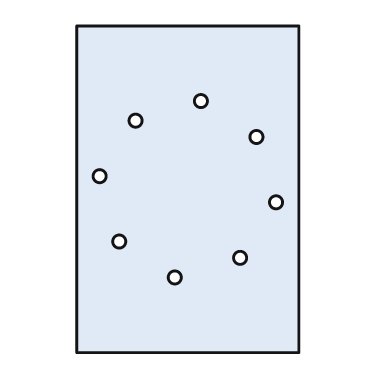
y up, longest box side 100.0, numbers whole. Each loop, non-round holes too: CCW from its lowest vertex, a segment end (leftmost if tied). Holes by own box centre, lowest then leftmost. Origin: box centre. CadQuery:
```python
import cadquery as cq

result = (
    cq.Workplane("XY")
    .moveTo(-34.0, -50.0)
    .lineTo(34.0, -50.0)
    .lineTo(34.0, 50.0)
    .lineTo(-34.0, 50.0)
    .close()
    .moveTo(-4.0, -27.0)
    .circle(2.0)
    .moveTo(16.0, -21.0)
    .circle(2.0)
    .moveTo(-21.0, -16.0)
    .circle(2.0)
    .moveTo(27.0, -4.0)
    .circle(2.0)
    .moveTo(-27.0, 4.0)
    .circle(2.0)
    .moveTo(21.0, 16.0)
    .circle(2.0)
    .moveTo(-16.0, 21.0)
    .circle(2.0)
    .moveTo(4.0, 27.0)
    .circle(2.0)
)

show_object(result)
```